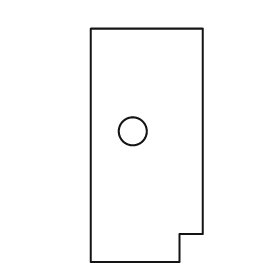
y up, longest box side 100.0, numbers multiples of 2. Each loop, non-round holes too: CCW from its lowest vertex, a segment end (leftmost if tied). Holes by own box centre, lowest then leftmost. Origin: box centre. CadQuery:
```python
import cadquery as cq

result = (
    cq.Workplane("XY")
    .moveTo(-24.0, -50.0)
    .lineTo(14.0, -50.0)
    .lineTo(14.0, -38.0)
    .lineTo(24.0, -38.0)
    .lineTo(24.0, 50.0)
    .lineTo(-24.0, 50.0)
    .close()
    .moveTo(-6.0, 6.0)
    .circle(6.0)
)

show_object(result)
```